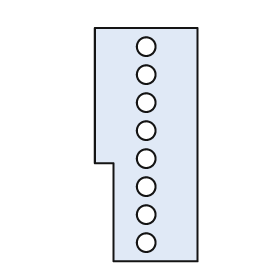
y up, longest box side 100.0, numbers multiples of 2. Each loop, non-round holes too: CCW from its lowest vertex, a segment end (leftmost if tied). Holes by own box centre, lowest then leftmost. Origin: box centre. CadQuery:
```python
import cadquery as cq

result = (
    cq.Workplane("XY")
    .moveTo(-14.0, -50.0)
    .lineTo(22.0, -50.0)
    .lineTo(22.0, 50.0)
    .lineTo(-22.0, 50.0)
    .lineTo(-22.0, -8.0)
    .lineTo(-14.0, -8.0)
    .close()
    .moveTo(0.0, -42.0)
    .circle(4.0)
    .moveTo(0.0, -30.0)
    .circle(4.0)
    .moveTo(0.0, -18.0)
    .circle(4.0)
    .moveTo(0.0, -6.0)
    .circle(4.0)
    .moveTo(0.0, 6.0)
    .circle(4.0)
    .moveTo(0.0, 18.0)
    .circle(4.0)
    .moveTo(0.0, 30.0)
    .circle(4.0)
    .moveTo(0.0, 42.0)
    .circle(4.0)
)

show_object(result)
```